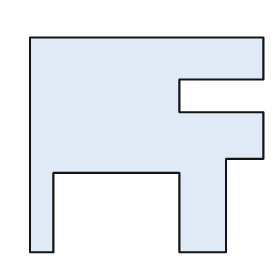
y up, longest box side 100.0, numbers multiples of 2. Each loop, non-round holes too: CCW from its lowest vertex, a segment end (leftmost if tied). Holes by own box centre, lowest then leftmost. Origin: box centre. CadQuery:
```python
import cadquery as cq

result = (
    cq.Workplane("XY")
    .moveTo(-50.0, -46.0)
    .lineTo(-40.0, -46.0)
    .lineTo(-40.0, -12.0)
    .lineTo(14.0, -12.0)
    .lineTo(14.0, -46.0)
    .lineTo(34.0, -46.0)
    .lineTo(34.0, -6.0)
    .lineTo(50.0, -6.0)
    .lineTo(50.0, 14.0)
    .lineTo(14.0, 14.0)
    .lineTo(14.0, 28.0)
    .lineTo(50.0, 28.0)
    .lineTo(50.0, 46.0)
    .lineTo(-50.0, 46.0)
    .close()
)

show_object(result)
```